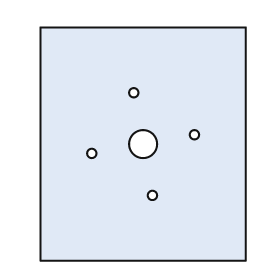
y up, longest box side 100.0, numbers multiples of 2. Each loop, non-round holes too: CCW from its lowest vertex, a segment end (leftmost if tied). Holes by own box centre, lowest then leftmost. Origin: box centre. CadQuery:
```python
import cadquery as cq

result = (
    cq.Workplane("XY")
    .moveTo(-44.0, -50.0)
    .lineTo(44.0, -50.0)
    .lineTo(44.0, 50.0)
    .lineTo(-44.0, 50.0)
    .close()
    .moveTo(4.0, -22.0)
    .circle(2.0)
    .moveTo(-22.0, -4.0)
    .circle(2.0)
    .moveTo(0.0, 0.0)
    .circle(6.0)
    .moveTo(22.0, 4.0)
    .circle(2.0)
    .moveTo(-4.0, 22.0)
    .circle(2.0)
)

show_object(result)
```